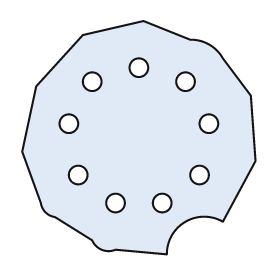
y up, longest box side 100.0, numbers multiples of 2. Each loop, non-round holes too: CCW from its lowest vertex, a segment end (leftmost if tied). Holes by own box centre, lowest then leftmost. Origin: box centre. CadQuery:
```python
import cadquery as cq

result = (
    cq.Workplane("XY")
    .moveTo(12.0, -50.0)
    .threePointArc((20.0, -36.0), (36.0, -36.0))
    .lineTo(50.0, -10.0)
    .lineTo(48.0, 18.0)
    .lineTo(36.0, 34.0)
    .threePointArc((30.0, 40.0), (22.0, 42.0))
    .lineTo(2.0, 50.0)
    .lineTo(-24.0, 44.0)
    .lineTo(-44.0, 22.0)
    .lineTo(-50.0, -6.0)
    .lineTo(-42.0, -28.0)
    .threePointArc((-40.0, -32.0), (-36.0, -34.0))
    .lineTo(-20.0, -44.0)
    .threePointArc((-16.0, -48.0), (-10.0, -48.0))
    .close()
    .moveTo(-10.0, -28.0)
    .circle(4.0)
    .moveTo(10.0, -28.0)
    .circle(4.0)
    .moveTo(-26.0, -16.0)
    .circle(4.0)
    .moveTo(26.0, -16.0)
    .circle(4.0)
    .moveTo(-30.0, 6.0)
    .circle(4.0)
    .moveTo(30.0, 6.0)
    .circle(4.0)
    .moveTo(-20.0, 24.0)
    .circle(4.0)
    .moveTo(20.0, 24.0)
    .circle(4.0)
    .moveTo(0.0, 30.0)
    .circle(4.0)
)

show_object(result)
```